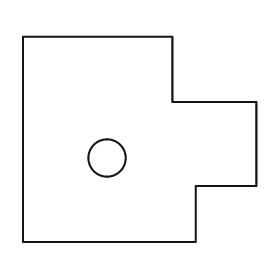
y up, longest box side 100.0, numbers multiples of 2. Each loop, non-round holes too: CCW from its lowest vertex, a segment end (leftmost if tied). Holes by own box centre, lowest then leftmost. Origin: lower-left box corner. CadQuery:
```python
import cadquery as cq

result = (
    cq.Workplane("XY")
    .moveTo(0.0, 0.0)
    .lineTo(74.0, 0.0)
    .lineTo(74.0, 24.0)
    .lineTo(100.0, 24.0)
    .lineTo(100.0, 60.0)
    .lineTo(64.0, 60.0)
    .lineTo(64.0, 88.0)
    .lineTo(0.0, 88.0)
    .close()
    .moveTo(36.0, 36.0)
    .circle(8.0)
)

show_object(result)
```